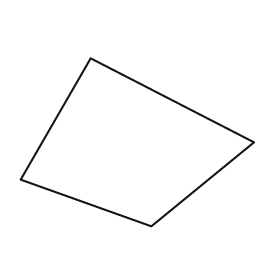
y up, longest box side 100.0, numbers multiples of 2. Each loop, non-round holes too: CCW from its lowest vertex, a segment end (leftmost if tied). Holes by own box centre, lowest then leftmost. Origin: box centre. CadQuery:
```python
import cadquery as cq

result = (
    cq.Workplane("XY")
    .moveTo(6.0, -36.0)
    .lineTo(50.0, 0.0)
    .lineTo(-20.0, 36.0)
    .lineTo(-50.0, -16.0)
    .close()
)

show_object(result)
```